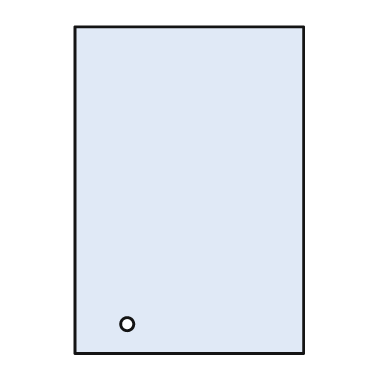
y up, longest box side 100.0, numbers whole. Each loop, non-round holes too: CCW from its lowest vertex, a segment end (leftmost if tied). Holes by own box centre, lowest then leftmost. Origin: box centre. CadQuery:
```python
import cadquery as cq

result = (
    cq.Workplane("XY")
    .moveTo(-35.0, -50.0)
    .lineTo(35.0, -50.0)
    .lineTo(35.0, 50.0)
    .lineTo(-35.0, 50.0)
    .close()
    .moveTo(-19.0, -41.0)
    .circle(2.0)
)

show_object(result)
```